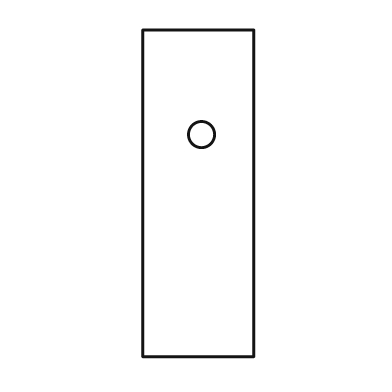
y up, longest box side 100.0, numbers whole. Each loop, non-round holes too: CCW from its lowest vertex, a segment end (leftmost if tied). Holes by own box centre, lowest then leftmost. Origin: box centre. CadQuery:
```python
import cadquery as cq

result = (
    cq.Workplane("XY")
    .moveTo(-17.0, -50.0)
    .lineTo(17.0, -50.0)
    .lineTo(17.0, 50.0)
    .lineTo(-17.0, 50.0)
    .close()
    .moveTo(1.0, 18.0)
    .circle(4.0)
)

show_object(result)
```